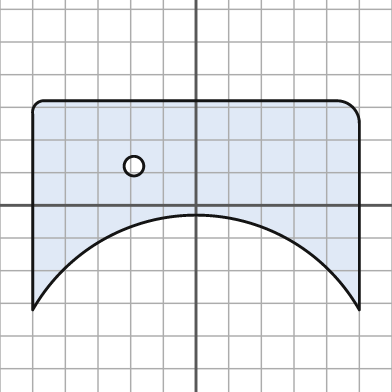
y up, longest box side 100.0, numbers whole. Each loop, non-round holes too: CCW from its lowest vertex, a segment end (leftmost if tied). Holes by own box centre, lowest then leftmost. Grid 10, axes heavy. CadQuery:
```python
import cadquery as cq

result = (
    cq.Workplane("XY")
    .moveTo(-50.0, -32.0)
    .threePointArc((0.0, -3.0), (50.0, -32.0))
    .lineTo(50.0, 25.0)
    .threePointArc((48.0, 30.0), (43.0, 32.0))
    .lineTo(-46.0, 32.0)
    .threePointArc((-49.0, 31.0), (-50.0, 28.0))
    .close()
    .moveTo(-19.0, 12.0)
    .circle(3.0)
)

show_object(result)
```